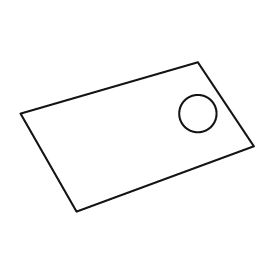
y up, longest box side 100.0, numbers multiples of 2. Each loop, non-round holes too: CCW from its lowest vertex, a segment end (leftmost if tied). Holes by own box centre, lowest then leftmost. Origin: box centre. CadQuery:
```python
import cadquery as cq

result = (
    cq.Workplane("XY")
    .moveTo(-26.0, -32.0)
    .lineTo(50.0, -4.0)
    .lineTo(26.0, 32.0)
    .lineTo(-50.0, 10.0)
    .close()
    .moveTo(26.0, 10.0)
    .circle(8.0)
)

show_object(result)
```